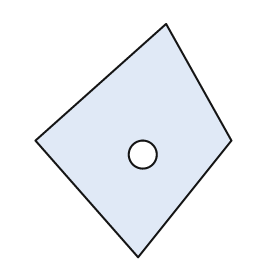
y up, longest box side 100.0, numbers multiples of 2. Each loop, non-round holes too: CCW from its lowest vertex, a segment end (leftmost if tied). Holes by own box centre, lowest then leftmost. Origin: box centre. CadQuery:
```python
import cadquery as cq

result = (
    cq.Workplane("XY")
    .moveTo(2.0, -50.0)
    .lineTo(42.0, 0.0)
    .lineTo(14.0, 50.0)
    .lineTo(-42.0, 0.0)
    .close()
    .moveTo(4.0, -6.0)
    .circle(6.0)
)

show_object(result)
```